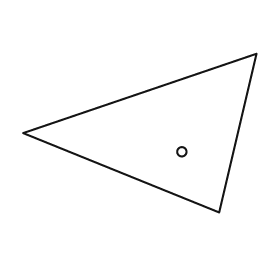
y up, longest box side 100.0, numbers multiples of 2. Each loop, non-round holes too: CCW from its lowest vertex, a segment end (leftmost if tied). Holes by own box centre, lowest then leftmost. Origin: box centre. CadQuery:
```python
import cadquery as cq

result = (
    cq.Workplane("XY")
    .moveTo(34.0, -34.0)
    .lineTo(50.0, 34.0)
    .lineTo(-50.0, 0.0)
    .close()
    .moveTo(18.0, -8.0)
    .circle(2.0)
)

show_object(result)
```